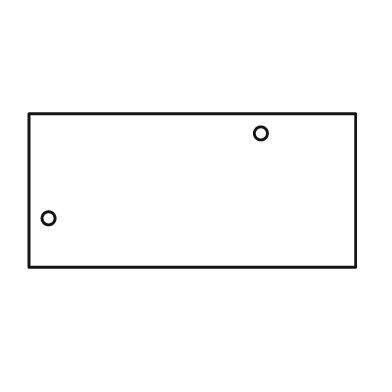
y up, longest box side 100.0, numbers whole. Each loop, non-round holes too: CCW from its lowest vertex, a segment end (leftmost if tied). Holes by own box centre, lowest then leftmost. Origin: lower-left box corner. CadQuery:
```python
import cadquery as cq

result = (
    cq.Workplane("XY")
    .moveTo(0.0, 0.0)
    .lineTo(100.0, 0.0)
    .lineTo(100.0, 47.0)
    .lineTo(0.0, 47.0)
    .close()
    .moveTo(6.0, 15.0)
    .circle(2.0)
    .moveTo(71.0, 41.0)
    .circle(2.0)
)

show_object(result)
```